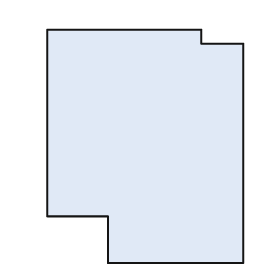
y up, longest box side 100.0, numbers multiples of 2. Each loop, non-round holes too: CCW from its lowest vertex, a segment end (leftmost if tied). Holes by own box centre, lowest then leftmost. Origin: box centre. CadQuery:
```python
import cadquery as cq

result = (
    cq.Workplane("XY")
    .moveTo(-16.0, -50.0)
    .lineTo(42.0, -50.0)
    .lineTo(42.0, 44.0)
    .lineTo(24.0, 44.0)
    .lineTo(24.0, 50.0)
    .lineTo(-42.0, 50.0)
    .lineTo(-42.0, -30.0)
    .lineTo(-16.0, -30.0)
    .close()
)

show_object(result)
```